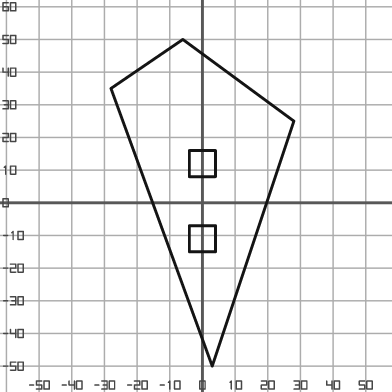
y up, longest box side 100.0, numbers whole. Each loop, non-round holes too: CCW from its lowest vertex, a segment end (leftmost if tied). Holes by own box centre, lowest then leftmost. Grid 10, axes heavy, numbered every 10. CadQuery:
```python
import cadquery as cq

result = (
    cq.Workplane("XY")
    .moveTo(3.0, -50.0)
    .lineTo(28.0, 25.0)
    .lineTo(-6.0, 50.0)
    .lineTo(-28.0, 35.0)
    .close()
    .moveTo(-4.0, -15.0)
    .lineTo(4.0, -15.0)
    .lineTo(4.0, -7.0)
    .lineTo(-4.0, -7.0)
    .close()
    .moveTo(-4.0, 8.0)
    .lineTo(4.0, 8.0)
    .lineTo(4.0, 16.0)
    .lineTo(-4.0, 16.0)
    .close()
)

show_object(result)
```